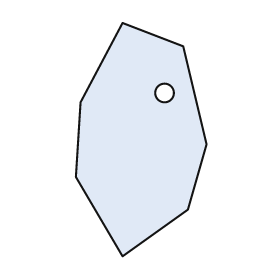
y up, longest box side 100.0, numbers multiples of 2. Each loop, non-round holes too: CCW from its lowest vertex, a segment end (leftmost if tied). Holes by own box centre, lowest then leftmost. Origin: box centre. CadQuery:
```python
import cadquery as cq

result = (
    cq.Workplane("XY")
    .moveTo(-8.0, -50.0)
    .lineTo(20.0, -30.0)
    .lineTo(28.0, -2.0)
    .lineTo(18.0, 40.0)
    .lineTo(-8.0, 50.0)
    .lineTo(-26.0, 16.0)
    .lineTo(-28.0, -16.0)
    .close()
    .moveTo(10.0, 20.0)
    .circle(4.0)
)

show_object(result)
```